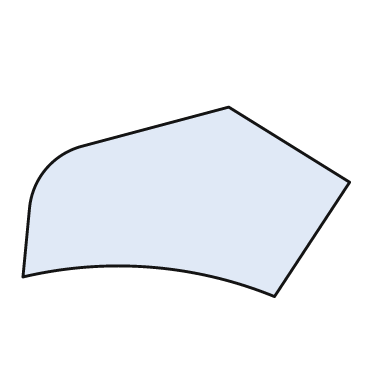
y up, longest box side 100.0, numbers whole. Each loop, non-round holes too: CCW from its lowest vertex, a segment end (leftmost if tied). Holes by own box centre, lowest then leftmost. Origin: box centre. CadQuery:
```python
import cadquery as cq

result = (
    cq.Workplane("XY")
    .moveTo(27.0, -29.0)
    .lineTo(50.0, 6.0)
    .lineTo(13.0, 29.0)
    .lineTo(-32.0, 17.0)
    .threePointArc((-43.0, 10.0), (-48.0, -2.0))
    .lineTo(-50.0, -23.0)
    .threePointArc((-11.0, -20.0), (27.0, -29.0))
    .close()
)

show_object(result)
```